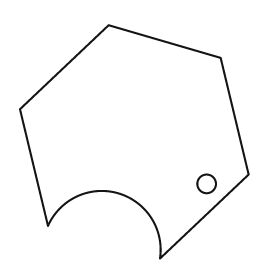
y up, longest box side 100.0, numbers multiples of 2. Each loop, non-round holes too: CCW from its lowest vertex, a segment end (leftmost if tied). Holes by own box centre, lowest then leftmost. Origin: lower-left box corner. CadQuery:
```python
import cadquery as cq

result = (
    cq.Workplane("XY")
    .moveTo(60.0, 0.0)
    .lineTo(98.0, 36.0)
    .lineTo(86.0, 86.0)
    .lineTo(38.0, 100.0)
    .lineTo(0.0, 64.0)
    .lineTo(12.0, 14.0)
    .threePointArc((42.0, 28.0), (60.0, 0.0))
    .close()
    .moveTo(80.0, 32.0)
    .circle(4.0)
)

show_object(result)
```